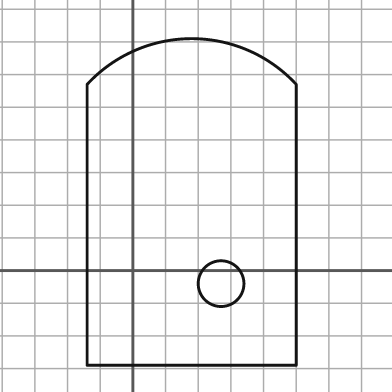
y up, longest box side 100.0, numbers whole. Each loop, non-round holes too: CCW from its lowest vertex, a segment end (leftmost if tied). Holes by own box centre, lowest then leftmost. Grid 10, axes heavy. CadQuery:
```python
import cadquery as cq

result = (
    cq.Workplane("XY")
    .moveTo(-14.0, -29.0)
    .lineTo(50.0, -29.0)
    .lineTo(50.0, 57.0)
    .threePointArc((18.0, 71.0), (-14.0, 57.0))
    .close()
    .moveTo(27.0, -4.0)
    .circle(7.0)
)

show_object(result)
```